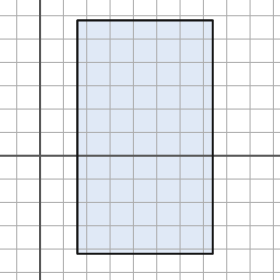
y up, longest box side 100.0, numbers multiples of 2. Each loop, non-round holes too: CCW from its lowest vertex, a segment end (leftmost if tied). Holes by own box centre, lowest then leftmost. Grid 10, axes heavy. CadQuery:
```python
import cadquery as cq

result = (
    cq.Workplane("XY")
    .moveTo(16.0, -42.0)
    .lineTo(74.0, -42.0)
    .lineTo(74.0, 58.0)
    .lineTo(16.0, 58.0)
    .close()
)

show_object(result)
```